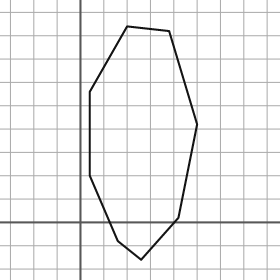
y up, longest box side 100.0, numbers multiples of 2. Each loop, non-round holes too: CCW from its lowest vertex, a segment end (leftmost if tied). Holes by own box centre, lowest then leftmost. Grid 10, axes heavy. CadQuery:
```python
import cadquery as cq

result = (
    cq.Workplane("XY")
    .moveTo(26.0, -16.0)
    .lineTo(42.0, 2.0)
    .lineTo(50.0, 42.0)
    .lineTo(38.0, 82.0)
    .lineTo(20.0, 84.0)
    .lineTo(4.0, 56.0)
    .lineTo(4.0, 20.0)
    .lineTo(16.0, -8.0)
    .close()
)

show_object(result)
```